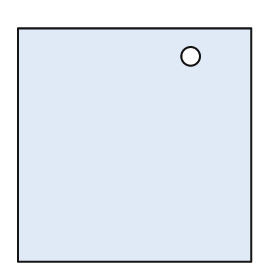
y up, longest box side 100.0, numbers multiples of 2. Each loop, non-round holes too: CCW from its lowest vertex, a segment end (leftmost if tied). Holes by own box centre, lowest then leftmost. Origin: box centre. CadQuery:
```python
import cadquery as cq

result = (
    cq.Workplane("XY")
    .moveTo(-50.0, -50.0)
    .lineTo(50.0, -50.0)
    .lineTo(50.0, 50.0)
    .lineTo(-50.0, 50.0)
    .close()
    .moveTo(24.0, 38.0)
    .circle(4.0)
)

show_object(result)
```